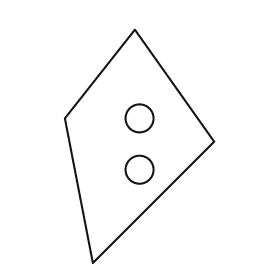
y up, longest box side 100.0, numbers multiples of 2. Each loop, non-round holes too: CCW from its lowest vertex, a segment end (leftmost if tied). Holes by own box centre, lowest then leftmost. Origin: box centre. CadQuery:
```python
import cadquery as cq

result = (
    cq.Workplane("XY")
    .moveTo(-20.0, -50.0)
    .lineTo(32.0, 2.0)
    .lineTo(-2.0, 50.0)
    .lineTo(-32.0, 12.0)
    .close()
    .moveTo(0.0, -10.0)
    .circle(6.0)
    .moveTo(0.0, 12.0)
    .circle(6.0)
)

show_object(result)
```